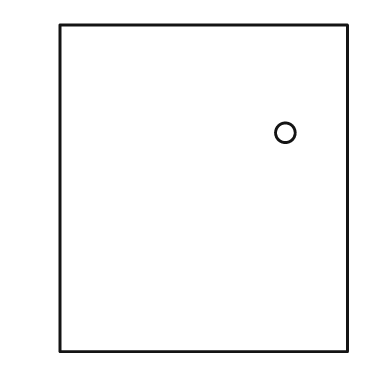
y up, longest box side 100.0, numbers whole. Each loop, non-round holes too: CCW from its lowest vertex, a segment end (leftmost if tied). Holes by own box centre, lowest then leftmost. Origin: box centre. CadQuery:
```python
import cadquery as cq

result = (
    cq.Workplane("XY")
    .moveTo(-44.0, -50.0)
    .lineTo(44.0, -50.0)
    .lineTo(44.0, 50.0)
    .lineTo(-44.0, 50.0)
    .close()
    .moveTo(25.0, 17.0)
    .circle(3.0)
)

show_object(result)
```